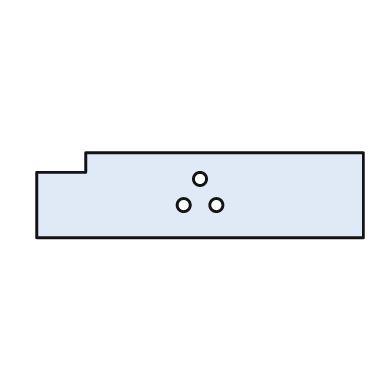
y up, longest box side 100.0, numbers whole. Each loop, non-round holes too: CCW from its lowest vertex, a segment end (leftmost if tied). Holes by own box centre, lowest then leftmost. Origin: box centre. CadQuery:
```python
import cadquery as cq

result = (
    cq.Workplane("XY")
    .moveTo(-50.0, -13.0)
    .lineTo(50.0, -13.0)
    .lineTo(50.0, 13.0)
    .lineTo(-35.0, 13.0)
    .lineTo(-35.0, 7.0)
    .lineTo(-50.0, 7.0)
    .close()
    .moveTo(-5.0, -3.0)
    .circle(2.0)
    .moveTo(5.0, -3.0)
    .circle(2.0)
    .moveTo(0.0, 5.0)
    .circle(2.0)
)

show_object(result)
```